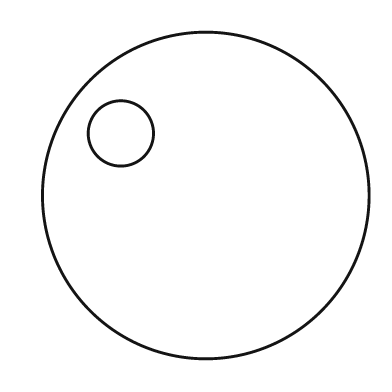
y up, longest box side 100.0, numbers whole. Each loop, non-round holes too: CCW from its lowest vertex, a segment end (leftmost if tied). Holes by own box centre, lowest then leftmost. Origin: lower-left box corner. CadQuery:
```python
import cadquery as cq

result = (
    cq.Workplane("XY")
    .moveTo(50.0, 50.0)
    .circle(50.0)
    .moveTo(24.0, 69.0)
    .circle(10.0)
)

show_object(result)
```